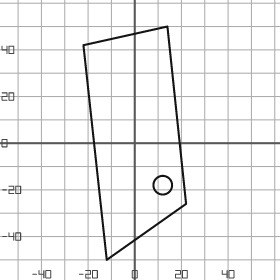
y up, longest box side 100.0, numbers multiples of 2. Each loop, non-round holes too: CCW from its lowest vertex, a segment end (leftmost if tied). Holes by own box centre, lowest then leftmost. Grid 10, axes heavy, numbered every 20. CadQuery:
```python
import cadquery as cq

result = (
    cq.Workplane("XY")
    .moveTo(-12.0, -50.0)
    .lineTo(22.0, -26.0)
    .lineTo(14.0, 50.0)
    .lineTo(-22.0, 42.0)
    .close()
    .moveTo(12.0, -18.0)
    .circle(4.0)
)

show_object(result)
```